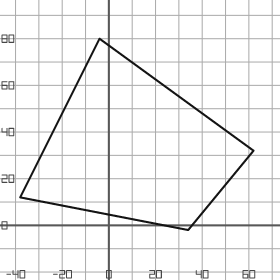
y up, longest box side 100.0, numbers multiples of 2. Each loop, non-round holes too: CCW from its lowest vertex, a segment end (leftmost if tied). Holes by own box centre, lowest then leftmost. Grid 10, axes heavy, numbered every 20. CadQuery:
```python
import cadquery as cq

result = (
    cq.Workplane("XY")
    .moveTo(34.0, -2.0)
    .lineTo(62.0, 32.0)
    .lineTo(-4.0, 80.0)
    .lineTo(-38.0, 12.0)
    .close()
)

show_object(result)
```